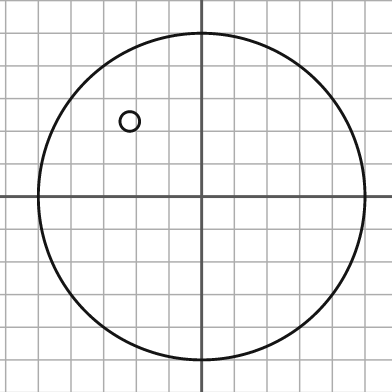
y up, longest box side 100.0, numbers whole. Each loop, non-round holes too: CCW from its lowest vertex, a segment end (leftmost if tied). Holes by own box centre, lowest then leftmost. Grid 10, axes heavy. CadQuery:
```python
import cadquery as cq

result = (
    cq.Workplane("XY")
    .moveTo(0.0, 0.0)
    .circle(50.0)
    .moveTo(-22.0, 23.0)
    .circle(3.0)
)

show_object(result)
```